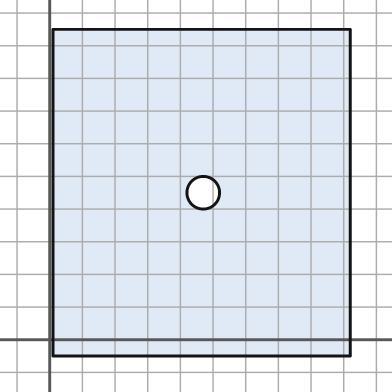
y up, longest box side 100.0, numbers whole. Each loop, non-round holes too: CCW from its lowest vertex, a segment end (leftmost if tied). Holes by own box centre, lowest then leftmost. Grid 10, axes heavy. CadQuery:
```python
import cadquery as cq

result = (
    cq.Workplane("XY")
    .moveTo(1.0, -5.0)
    .lineTo(92.0, -5.0)
    .lineTo(92.0, 95.0)
    .lineTo(1.0, 95.0)
    .close()
    .moveTo(47.0, 45.0)
    .circle(5.0)
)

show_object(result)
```